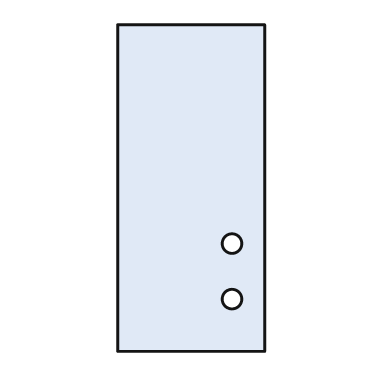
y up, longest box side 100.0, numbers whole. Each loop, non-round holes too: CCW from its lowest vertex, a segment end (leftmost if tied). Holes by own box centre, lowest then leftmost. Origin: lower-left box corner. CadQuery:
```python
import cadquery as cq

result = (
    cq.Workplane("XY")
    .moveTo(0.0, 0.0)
    .lineTo(45.0, 0.0)
    .lineTo(45.0, 100.0)
    .lineTo(0.0, 100.0)
    .close()
    .moveTo(35.0, 16.0)
    .circle(3.0)
    .moveTo(35.0, 33.0)
    .circle(3.0)
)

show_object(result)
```